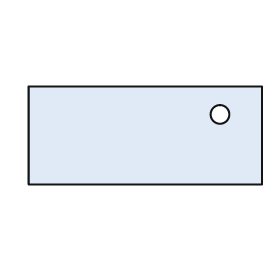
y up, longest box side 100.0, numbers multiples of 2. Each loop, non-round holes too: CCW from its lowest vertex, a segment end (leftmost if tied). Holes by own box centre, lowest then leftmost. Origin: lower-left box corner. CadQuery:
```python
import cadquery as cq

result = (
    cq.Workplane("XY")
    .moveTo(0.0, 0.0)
    .lineTo(100.0, 0.0)
    .lineTo(100.0, 42.0)
    .lineTo(0.0, 42.0)
    .close()
    .moveTo(82.0, 30.0)
    .circle(4.0)
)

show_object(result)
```